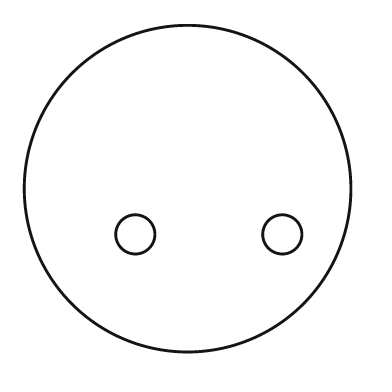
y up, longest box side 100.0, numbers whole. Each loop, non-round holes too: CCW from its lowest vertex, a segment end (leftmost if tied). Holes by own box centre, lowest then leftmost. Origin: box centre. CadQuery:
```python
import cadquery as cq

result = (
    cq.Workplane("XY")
    .moveTo(0.0, 0.0)
    .circle(50.0)
    .moveTo(-16.0, -14.0)
    .circle(6.0)
    .moveTo(29.0, -14.0)
    .circle(6.0)
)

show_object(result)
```